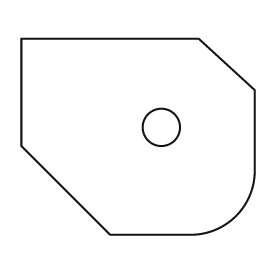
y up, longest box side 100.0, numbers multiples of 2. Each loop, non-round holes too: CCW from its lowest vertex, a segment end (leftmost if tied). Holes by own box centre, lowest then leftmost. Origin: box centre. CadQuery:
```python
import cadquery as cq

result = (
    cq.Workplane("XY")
    .moveTo(-12.0, -42.0)
    .lineTo(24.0, -42.0)
    .threePointArc((42.0, -34.0), (50.0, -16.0))
    .lineTo(50.0, 20.0)
    .lineTo(26.0, 42.0)
    .lineTo(-50.0, 42.0)
    .lineTo(-50.0, -4.0)
    .close()
    .moveTo(10.0, 4.0)
    .circle(8.0)
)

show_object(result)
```